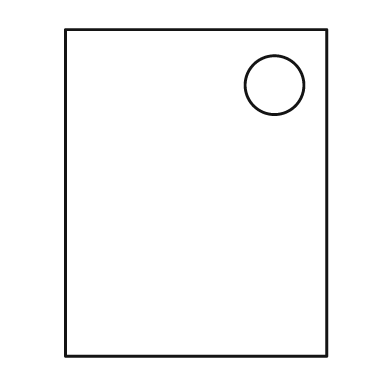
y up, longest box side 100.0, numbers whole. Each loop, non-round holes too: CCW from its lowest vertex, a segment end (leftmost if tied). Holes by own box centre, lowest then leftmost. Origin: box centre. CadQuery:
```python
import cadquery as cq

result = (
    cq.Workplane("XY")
    .moveTo(-40.0, -50.0)
    .lineTo(40.0, -50.0)
    .lineTo(40.0, 50.0)
    .lineTo(-40.0, 50.0)
    .close()
    .moveTo(24.0, 33.0)
    .circle(9.0)
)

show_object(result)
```